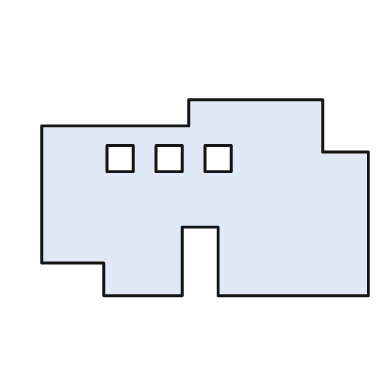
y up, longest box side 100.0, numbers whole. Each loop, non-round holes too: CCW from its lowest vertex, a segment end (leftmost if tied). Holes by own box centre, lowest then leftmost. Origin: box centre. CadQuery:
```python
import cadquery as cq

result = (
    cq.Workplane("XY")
    .moveTo(-31.0, -30.0)
    .lineTo(-7.0, -30.0)
    .lineTo(-7.0, -9.0)
    .lineTo(4.0, -9.0)
    .lineTo(4.0, -30.0)
    .lineTo(50.0, -30.0)
    .lineTo(50.0, 14.0)
    .lineTo(36.0, 14.0)
    .lineTo(36.0, 30.0)
    .lineTo(-5.0, 30.0)
    .lineTo(-5.0, 22.0)
    .lineTo(-50.0, 22.0)
    .lineTo(-50.0, -20.0)
    .lineTo(-31.0, -20.0)
    .close()
    .moveTo(-30.0, 8.0)
    .lineTo(-22.0, 8.0)
    .lineTo(-22.0, 16.0)
    .lineTo(-30.0, 16.0)
    .close()
    .moveTo(-15.0, 8.0)
    .lineTo(-7.0, 8.0)
    .lineTo(-7.0, 16.0)
    .lineTo(-15.0, 16.0)
    .close()
    .moveTo(0.0, 8.0)
    .lineTo(8.0, 8.0)
    .lineTo(8.0, 16.0)
    .lineTo(0.0, 16.0)
    .close()
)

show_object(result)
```